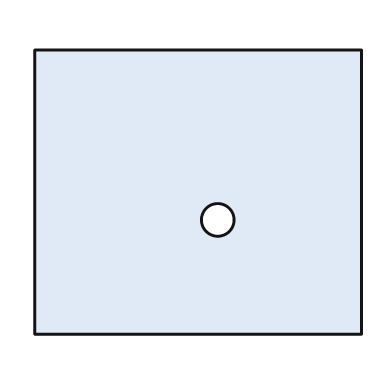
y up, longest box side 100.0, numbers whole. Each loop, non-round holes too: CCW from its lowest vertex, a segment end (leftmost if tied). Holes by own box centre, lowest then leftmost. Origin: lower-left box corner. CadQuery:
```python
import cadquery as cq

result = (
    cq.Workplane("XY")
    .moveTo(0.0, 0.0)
    .lineTo(100.0, 0.0)
    .lineTo(100.0, 87.0)
    .lineTo(0.0, 87.0)
    .close()
    .moveTo(56.0, 35.0)
    .circle(5.0)
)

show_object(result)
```